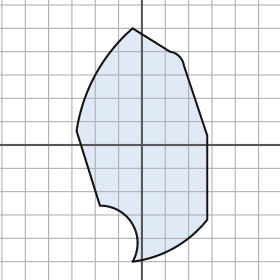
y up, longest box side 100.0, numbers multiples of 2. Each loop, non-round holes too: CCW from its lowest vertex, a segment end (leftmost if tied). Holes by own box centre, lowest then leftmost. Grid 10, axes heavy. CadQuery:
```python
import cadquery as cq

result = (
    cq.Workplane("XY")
    .moveTo(-4.0, -50.0)
    .threePointArc((14.0, -44.0), (28.0, -32.0))
    .lineTo(28.0, 4.0)
    .lineTo(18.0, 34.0)
    .threePointArc((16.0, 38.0), (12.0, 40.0))
    .lineTo(-4.0, 50.0)
    .threePointArc((-20.0, 30.0), (-28.0, 6.0))
    .lineTo(-18.0, -26.0)
    .threePointArc((-4.0, -34.0), (-4.0, -50.0))
    .close()
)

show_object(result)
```